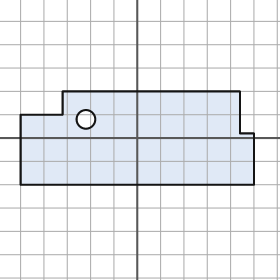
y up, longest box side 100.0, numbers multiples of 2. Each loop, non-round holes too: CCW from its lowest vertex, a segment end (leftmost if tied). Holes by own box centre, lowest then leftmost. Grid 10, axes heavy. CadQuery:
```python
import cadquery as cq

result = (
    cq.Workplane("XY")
    .moveTo(-50.0, -20.0)
    .lineTo(50.0, -20.0)
    .lineTo(50.0, 2.0)
    .lineTo(44.0, 2.0)
    .lineTo(44.0, 20.0)
    .lineTo(-32.0, 20.0)
    .lineTo(-32.0, 10.0)
    .lineTo(-50.0, 10.0)
    .close()
    .moveTo(-22.0, 8.0)
    .circle(4.0)
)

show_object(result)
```